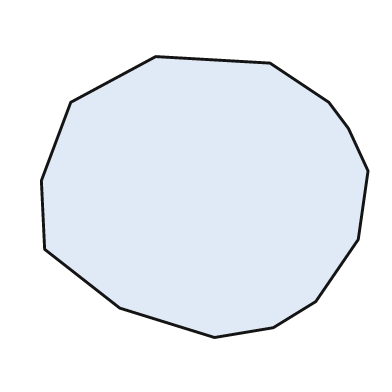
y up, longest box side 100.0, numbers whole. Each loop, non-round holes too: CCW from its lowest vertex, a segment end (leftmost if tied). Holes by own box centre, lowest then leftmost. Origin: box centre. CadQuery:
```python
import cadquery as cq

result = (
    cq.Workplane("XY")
    .moveTo(3.0, -43.0)
    .lineTo(21.0, -40.0)
    .lineTo(34.0, -32.0)
    .lineTo(47.0, -13.0)
    .lineTo(50.0, 8.0)
    .lineTo(44.0, 21.0)
    .lineTo(38.0, 29.0)
    .lineTo(20.0, 41.0)
    .lineTo(-15.0, 43.0)
    .lineTo(-41.0, 29.0)
    .lineTo(-50.0, 5.0)
    .lineTo(-49.0, -16.0)
    .lineTo(-26.0, -34.0)
    .close()
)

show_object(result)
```